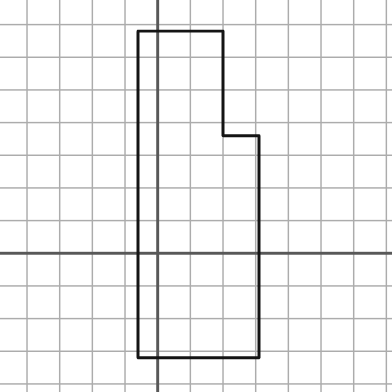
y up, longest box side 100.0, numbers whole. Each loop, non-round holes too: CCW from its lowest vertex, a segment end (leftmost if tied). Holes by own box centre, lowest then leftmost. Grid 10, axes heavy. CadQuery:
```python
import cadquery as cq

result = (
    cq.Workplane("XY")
    .moveTo(-6.0, -32.0)
    .lineTo(31.0, -32.0)
    .lineTo(31.0, 36.0)
    .lineTo(20.0, 36.0)
    .lineTo(20.0, 68.0)
    .lineTo(-6.0, 68.0)
    .close()
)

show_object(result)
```